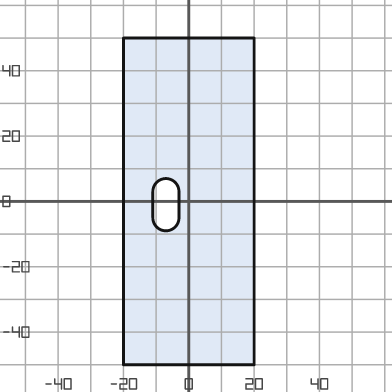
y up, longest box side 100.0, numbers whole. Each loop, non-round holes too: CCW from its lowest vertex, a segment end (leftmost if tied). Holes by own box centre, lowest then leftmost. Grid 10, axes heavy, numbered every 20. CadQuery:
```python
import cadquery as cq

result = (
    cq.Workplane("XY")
    .moveTo(-20.0, -50.0)
    .lineTo(20.0, -50.0)
    .lineTo(20.0, 50.0)
    .lineTo(-20.0, 50.0)
    .close()
    .moveTo(-11.0, -5.0)
    .threePointArc((-7.0, -9.0), (-3.0, -5.0))
    .lineTo(-3.0, 3.0)
    .threePointArc((-7.0, 7.0), (-11.0, 3.0))
    .close()
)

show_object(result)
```